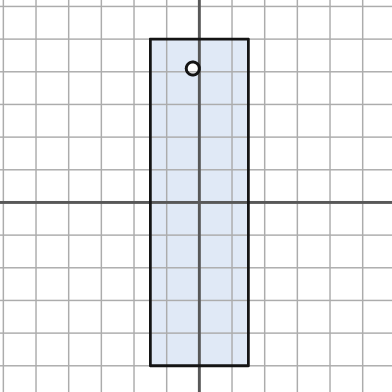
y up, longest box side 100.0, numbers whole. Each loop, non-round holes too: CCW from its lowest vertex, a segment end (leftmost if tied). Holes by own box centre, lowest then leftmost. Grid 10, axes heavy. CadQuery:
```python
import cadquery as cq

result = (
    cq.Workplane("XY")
    .moveTo(-15.0, -50.0)
    .lineTo(15.0, -50.0)
    .lineTo(15.0, 50.0)
    .lineTo(-15.0, 50.0)
    .close()
    .moveTo(-2.0, 41.0)
    .circle(2.0)
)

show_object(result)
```